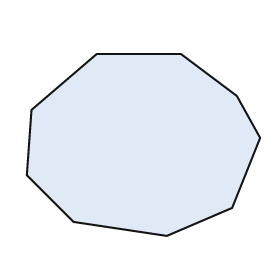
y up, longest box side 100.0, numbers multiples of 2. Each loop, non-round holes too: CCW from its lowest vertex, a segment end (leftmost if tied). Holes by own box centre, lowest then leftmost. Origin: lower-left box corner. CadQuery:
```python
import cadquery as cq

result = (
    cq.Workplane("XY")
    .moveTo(60.0, 0.0)
    .lineTo(88.0, 12.0)
    .lineTo(100.0, 42.0)
    .lineTo(90.0, 60.0)
    .lineTo(66.0, 78.0)
    .lineTo(30.0, 78.0)
    .lineTo(2.0, 54.0)
    .lineTo(0.0, 26.0)
    .lineTo(20.0, 6.0)
    .close()
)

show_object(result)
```